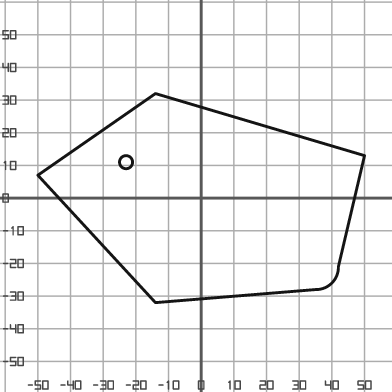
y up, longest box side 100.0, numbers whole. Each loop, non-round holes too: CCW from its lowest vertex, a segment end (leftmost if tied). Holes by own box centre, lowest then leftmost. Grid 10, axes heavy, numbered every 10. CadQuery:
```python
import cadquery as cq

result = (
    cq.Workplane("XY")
    .moveTo(-14.0, -32.0)
    .lineTo(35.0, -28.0)
    .threePointArc((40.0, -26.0), (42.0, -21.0))
    .lineTo(50.0, 13.0)
    .lineTo(-14.0, 32.0)
    .lineTo(-50.0, 7.0)
    .close()
    .moveTo(-23.0, 11.0)
    .circle(2.0)
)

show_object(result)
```